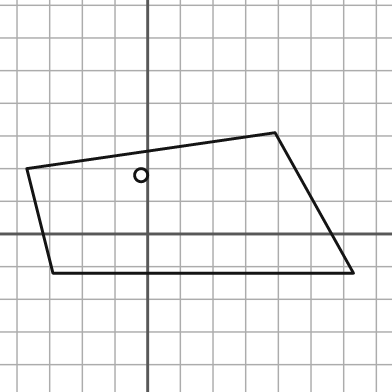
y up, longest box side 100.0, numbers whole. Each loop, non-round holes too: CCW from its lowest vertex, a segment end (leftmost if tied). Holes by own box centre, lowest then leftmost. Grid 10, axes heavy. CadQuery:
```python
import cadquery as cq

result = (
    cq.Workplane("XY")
    .moveTo(-29.0, -12.0)
    .lineTo(63.0, -12.0)
    .lineTo(39.0, 31.0)
    .lineTo(-37.0, 20.0)
    .close()
    .moveTo(-2.0, 18.0)
    .circle(2.0)
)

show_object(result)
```